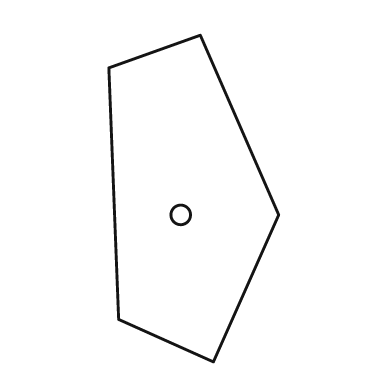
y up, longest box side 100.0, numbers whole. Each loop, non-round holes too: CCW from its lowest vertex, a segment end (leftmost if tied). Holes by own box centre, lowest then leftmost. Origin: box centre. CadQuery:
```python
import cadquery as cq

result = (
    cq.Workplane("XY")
    .moveTo(6.0, -50.0)
    .lineTo(26.0, -5.0)
    .lineTo(2.0, 50.0)
    .lineTo(-26.0, 40.0)
    .lineTo(-23.0, -37.0)
    .close()
    .moveTo(-4.0, -5.0)
    .circle(3.0)
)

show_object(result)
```